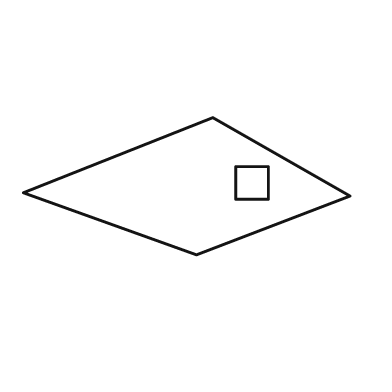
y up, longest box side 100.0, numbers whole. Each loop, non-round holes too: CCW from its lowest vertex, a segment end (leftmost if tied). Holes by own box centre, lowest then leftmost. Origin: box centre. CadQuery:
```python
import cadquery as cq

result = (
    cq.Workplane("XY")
    .moveTo(3.0, -21.0)
    .lineTo(50.0, -3.0)
    .lineTo(8.0, 21.0)
    .lineTo(-50.0, -2.0)
    .close()
    .moveTo(15.0, -4.0)
    .lineTo(25.0, -4.0)
    .lineTo(25.0, 6.0)
    .lineTo(15.0, 6.0)
    .close()
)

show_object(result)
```